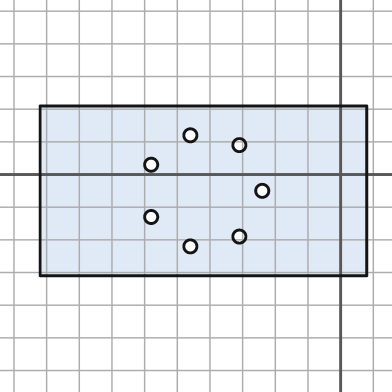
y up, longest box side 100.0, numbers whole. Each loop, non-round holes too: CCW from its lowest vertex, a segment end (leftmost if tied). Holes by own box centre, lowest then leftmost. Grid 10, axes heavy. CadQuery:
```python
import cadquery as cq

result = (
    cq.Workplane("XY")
    .moveTo(-92.0, -31.0)
    .lineTo(8.0, -31.0)
    .lineTo(8.0, 21.0)
    .lineTo(-92.0, 21.0)
    .close()
    .moveTo(-46.0, -22.0)
    .circle(2.0)
    .moveTo(-31.0, -19.0)
    .circle(2.0)
    .moveTo(-58.0, -13.0)
    .circle(2.0)
    .moveTo(-24.0, -5.0)
    .circle(2.0)
    .moveTo(-58.0, 3.0)
    .circle(2.0)
    .moveTo(-31.0, 9.0)
    .circle(2.0)
    .moveTo(-46.0, 12.0)
    .circle(2.0)
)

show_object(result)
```